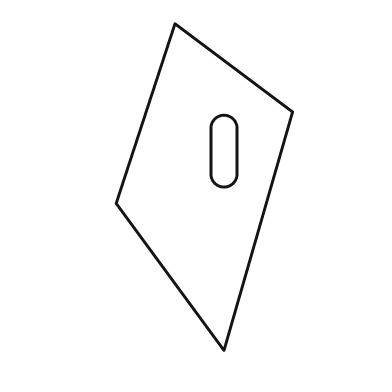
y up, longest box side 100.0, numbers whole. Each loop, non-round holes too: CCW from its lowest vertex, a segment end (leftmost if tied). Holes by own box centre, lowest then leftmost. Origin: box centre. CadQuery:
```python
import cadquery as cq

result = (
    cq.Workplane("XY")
    .moveTo(6.0, -50.0)
    .lineTo(27.0, 23.0)
    .lineTo(-9.0, 50.0)
    .lineTo(-27.0, -5.0)
    .close()
    .moveTo(2.0, 4.0)
    .threePointArc((6.0, 0.0), (10.0, 4.0))
    .lineTo(10.0, 18.0)
    .threePointArc((6.0, 22.0), (2.0, 18.0))
    .close()
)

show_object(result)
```